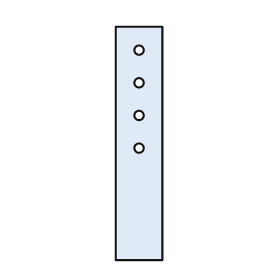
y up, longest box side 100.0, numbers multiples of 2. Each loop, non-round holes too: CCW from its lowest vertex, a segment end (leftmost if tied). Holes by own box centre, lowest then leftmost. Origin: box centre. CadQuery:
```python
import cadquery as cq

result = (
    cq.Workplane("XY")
    .moveTo(-10.0, -50.0)
    .lineTo(10.0, -50.0)
    .lineTo(10.0, 50.0)
    .lineTo(-10.0, 50.0)
    .close()
    .moveTo(0.0, -2.0)
    .circle(2.0)
    .moveTo(0.0, 12.0)
    .circle(2.0)
    .moveTo(0.0, 26.0)
    .circle(2.0)
    .moveTo(0.0, 40.0)
    .circle(2.0)
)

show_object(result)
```